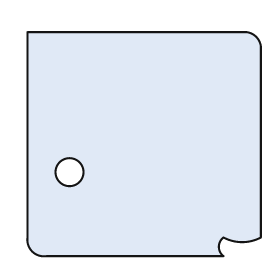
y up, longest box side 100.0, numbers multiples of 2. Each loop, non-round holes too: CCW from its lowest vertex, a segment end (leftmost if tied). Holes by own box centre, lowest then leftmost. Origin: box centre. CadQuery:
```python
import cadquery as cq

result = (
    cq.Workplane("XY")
    .moveTo(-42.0, -48.0)
    .lineTo(34.0, -48.0)
    .threePointArc((32.0, -44.0), (34.0, -40.0))
    .threePointArc((42.0, -42.0), (50.0, -40.0))
    .lineTo(50.0, 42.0)
    .threePointArc((48.0, 46.0), (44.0, 48.0))
    .lineTo(-50.0, 48.0)
    .lineTo(-50.0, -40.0)
    .threePointArc((-48.0, -46.0), (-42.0, -48.0))
    .close()
    .moveTo(-32.0, -12.0)
    .circle(6.0)
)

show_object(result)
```